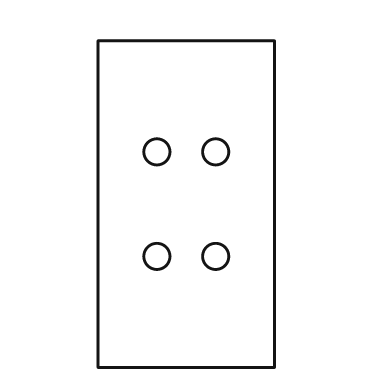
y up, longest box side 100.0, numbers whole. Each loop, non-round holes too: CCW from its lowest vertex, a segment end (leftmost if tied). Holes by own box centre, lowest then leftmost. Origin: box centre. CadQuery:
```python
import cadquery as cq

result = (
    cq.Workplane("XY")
    .moveTo(-27.0, -50.0)
    .lineTo(27.0, -50.0)
    .lineTo(27.0, 50.0)
    .lineTo(-27.0, 50.0)
    .close()
    .moveTo(-9.0, -16.0)
    .circle(4.0)
    .moveTo(9.0, -16.0)
    .circle(4.0)
    .moveTo(-9.0, 16.0)
    .circle(4.0)
    .moveTo(9.0, 16.0)
    .circle(4.0)
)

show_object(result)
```